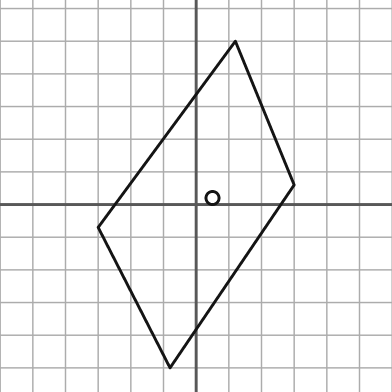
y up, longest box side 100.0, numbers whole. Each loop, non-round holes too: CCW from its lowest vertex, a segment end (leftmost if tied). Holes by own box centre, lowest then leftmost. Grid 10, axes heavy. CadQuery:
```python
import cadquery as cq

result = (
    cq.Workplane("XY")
    .moveTo(-8.0, -50.0)
    .lineTo(30.0, 6.0)
    .lineTo(12.0, 50.0)
    .lineTo(-30.0, -7.0)
    .close()
    .moveTo(5.0, 2.0)
    .circle(2.0)
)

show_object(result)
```